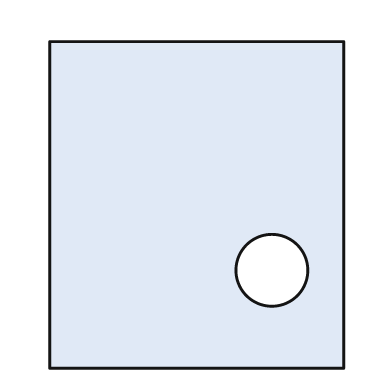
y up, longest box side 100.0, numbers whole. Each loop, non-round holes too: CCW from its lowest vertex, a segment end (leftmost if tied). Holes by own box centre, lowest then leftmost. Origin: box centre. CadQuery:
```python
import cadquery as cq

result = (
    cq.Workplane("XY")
    .moveTo(-45.0, -50.0)
    .lineTo(45.0, -50.0)
    .lineTo(45.0, 50.0)
    .lineTo(-45.0, 50.0)
    .close()
    .moveTo(23.0, -20.0)
    .circle(11.0)
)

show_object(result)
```